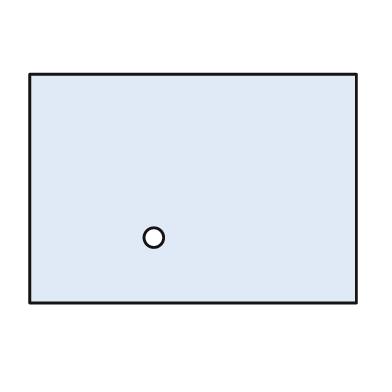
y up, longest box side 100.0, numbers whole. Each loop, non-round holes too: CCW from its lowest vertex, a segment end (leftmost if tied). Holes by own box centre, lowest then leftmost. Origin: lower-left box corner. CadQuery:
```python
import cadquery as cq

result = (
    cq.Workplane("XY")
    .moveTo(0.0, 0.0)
    .lineTo(100.0, 0.0)
    .lineTo(100.0, 70.0)
    .lineTo(0.0, 70.0)
    .close()
    .moveTo(38.0, 20.0)
    .circle(3.0)
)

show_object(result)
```